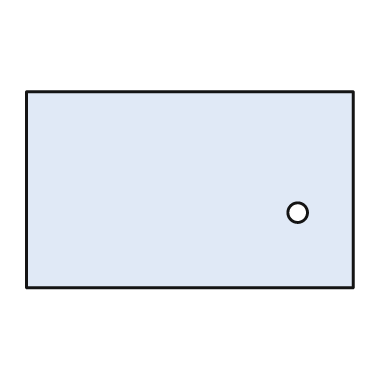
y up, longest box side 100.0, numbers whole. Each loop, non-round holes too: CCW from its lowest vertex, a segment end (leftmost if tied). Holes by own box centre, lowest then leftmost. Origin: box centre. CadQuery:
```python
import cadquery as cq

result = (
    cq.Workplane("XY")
    .moveTo(-50.0, -30.0)
    .lineTo(50.0, -30.0)
    .lineTo(50.0, 30.0)
    .lineTo(-50.0, 30.0)
    .close()
    .moveTo(33.0, -7.0)
    .circle(3.0)
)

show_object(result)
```